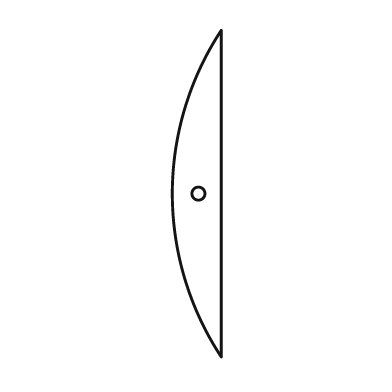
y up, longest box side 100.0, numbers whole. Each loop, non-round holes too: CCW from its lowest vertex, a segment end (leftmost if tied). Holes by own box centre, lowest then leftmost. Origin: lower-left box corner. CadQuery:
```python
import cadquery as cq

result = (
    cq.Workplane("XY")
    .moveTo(15.0, 0.0)
    .lineTo(15.0, 100.0)
    .threePointArc((0.0, 50.0), (15.0, 0.0))
    .close()
    .moveTo(8.0, 50.0)
    .circle(2.0)
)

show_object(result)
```